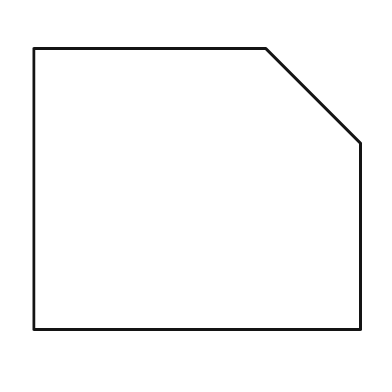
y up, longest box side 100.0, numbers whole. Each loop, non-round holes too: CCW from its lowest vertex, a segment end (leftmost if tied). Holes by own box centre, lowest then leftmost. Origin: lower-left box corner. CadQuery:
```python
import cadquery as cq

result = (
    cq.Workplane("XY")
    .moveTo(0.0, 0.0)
    .lineTo(100.0, 0.0)
    .lineTo(100.0, 57.0)
    .lineTo(71.0, 86.0)
    .lineTo(0.0, 86.0)
    .close()
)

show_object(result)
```